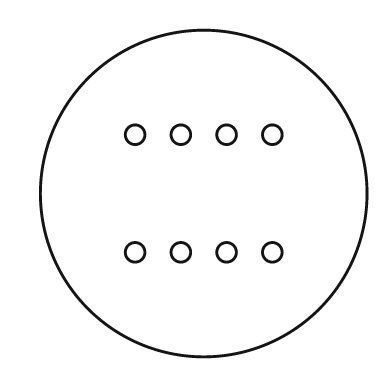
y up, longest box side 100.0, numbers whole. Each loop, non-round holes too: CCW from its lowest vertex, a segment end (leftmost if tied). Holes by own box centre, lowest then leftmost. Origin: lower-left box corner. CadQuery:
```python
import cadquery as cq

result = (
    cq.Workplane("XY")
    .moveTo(50.0, 50.0)
    .circle(50.0)
    .moveTo(29.0, 32.0)
    .circle(3.0)
    .moveTo(43.0, 32.0)
    .circle(3.0)
    .moveTo(57.0, 32.0)
    .circle(3.0)
    .moveTo(71.0, 32.0)
    .circle(3.0)
    .moveTo(29.0, 68.0)
    .circle(3.0)
    .moveTo(43.0, 68.0)
    .circle(3.0)
    .moveTo(57.0, 68.0)
    .circle(3.0)
    .moveTo(71.0, 68.0)
    .circle(3.0)
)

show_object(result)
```